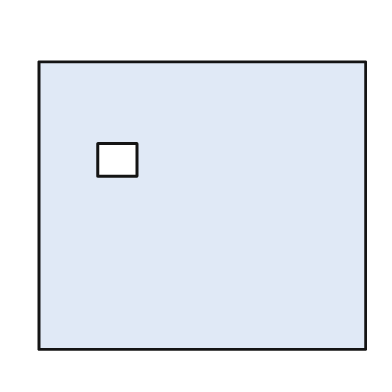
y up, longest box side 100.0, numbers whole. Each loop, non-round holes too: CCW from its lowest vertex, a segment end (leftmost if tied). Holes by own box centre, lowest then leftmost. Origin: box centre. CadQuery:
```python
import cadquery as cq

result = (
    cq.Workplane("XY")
    .moveTo(-50.0, -44.0)
    .lineTo(50.0, -44.0)
    .lineTo(50.0, 44.0)
    .lineTo(-50.0, 44.0)
    .close()
    .moveTo(-32.0, 9.0)
    .lineTo(-20.0, 9.0)
    .lineTo(-20.0, 19.0)
    .lineTo(-32.0, 19.0)
    .close()
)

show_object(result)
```